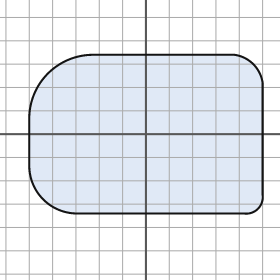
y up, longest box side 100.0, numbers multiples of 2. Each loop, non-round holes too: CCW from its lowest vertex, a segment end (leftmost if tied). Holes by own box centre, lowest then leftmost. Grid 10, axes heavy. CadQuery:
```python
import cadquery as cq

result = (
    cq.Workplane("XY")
    .moveTo(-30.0, -34.0)
    .lineTo(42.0, -34.0)
    .threePointArc((48.0, -32.0), (50.0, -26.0))
    .lineTo(50.0, 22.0)
    .threePointArc((46.0, 30.0), (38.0, 34.0))
    .lineTo(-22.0, 34.0)
    .threePointArc((-42.0, 26.0), (-50.0, 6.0))
    .lineTo(-50.0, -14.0)
    .threePointArc((-44.0, -28.0), (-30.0, -34.0))
    .close()
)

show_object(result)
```